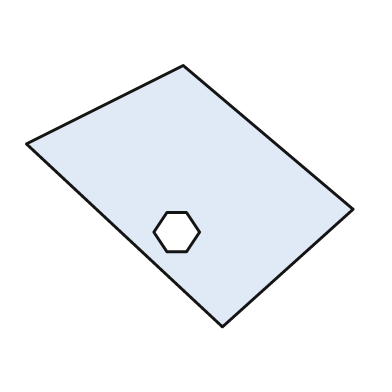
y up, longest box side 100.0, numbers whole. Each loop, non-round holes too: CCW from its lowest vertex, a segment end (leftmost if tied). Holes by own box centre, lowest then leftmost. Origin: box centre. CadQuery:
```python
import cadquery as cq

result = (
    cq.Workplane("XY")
    .moveTo(10.0, -40.0)
    .lineTo(50.0, -4.0)
    .lineTo(-2.0, 40.0)
    .lineTo(-50.0, 16.0)
    .close()
    .moveTo(-7.0, -17.0)
    .lineTo(-1.0, -17.0)
    .lineTo(3.0, -11.0)
    .lineTo(-1.0, -5.0)
    .lineTo(-7.0, -5.0)
    .lineTo(-11.0, -11.0)
    .close()
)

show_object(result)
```